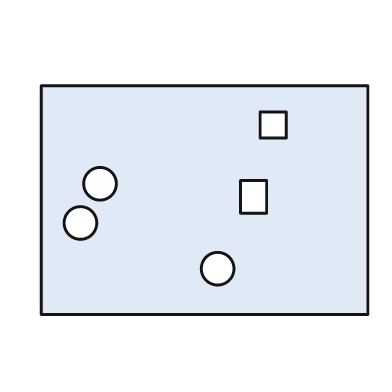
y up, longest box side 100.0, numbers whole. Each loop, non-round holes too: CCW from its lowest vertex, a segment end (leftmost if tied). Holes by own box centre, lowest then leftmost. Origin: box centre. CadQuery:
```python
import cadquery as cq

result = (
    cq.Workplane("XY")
    .moveTo(-50.0, -35.0)
    .lineTo(50.0, -35.0)
    .lineTo(50.0, 35.0)
    .lineTo(-50.0, 35.0)
    .close()
    .moveTo(4.0, -21.0)
    .circle(5.0)
    .moveTo(-38.0, -7.0)
    .circle(5.0)
    .moveTo(11.0, -4.0)
    .lineTo(19.0, -4.0)
    .lineTo(19.0, 6.0)
    .lineTo(11.0, 6.0)
    .close()
    .moveTo(-32.0, 5.0)
    .circle(5.0)
    .moveTo(17.0, 19.0)
    .lineTo(25.0, 19.0)
    .lineTo(25.0, 27.0)
    .lineTo(17.0, 27.0)
    .close()
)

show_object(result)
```